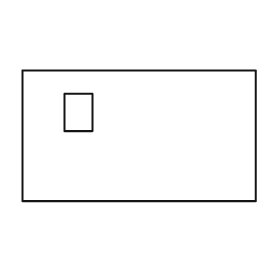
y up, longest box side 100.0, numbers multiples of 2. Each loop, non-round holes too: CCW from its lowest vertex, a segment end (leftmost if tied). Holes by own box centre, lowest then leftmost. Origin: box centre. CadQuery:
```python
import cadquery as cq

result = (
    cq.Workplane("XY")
    .moveTo(-50.0, -28.0)
    .lineTo(50.0, -28.0)
    .lineTo(50.0, 28.0)
    .lineTo(-50.0, 28.0)
    .close()
    .moveTo(-32.0, 2.0)
    .lineTo(-20.0, 2.0)
    .lineTo(-20.0, 18.0)
    .lineTo(-32.0, 18.0)
    .close()
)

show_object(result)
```